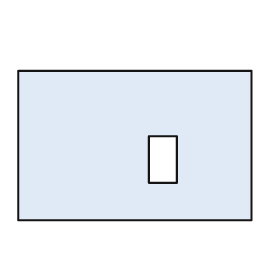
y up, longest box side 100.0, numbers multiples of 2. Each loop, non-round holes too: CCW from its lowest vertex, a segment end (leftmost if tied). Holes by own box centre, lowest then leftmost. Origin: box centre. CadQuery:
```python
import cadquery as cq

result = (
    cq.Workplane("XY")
    .moveTo(-50.0, -32.0)
    .lineTo(50.0, -32.0)
    .lineTo(50.0, 32.0)
    .lineTo(-50.0, 32.0)
    .close()
    .moveTo(6.0, -16.0)
    .lineTo(18.0, -16.0)
    .lineTo(18.0, 4.0)
    .lineTo(6.0, 4.0)
    .close()
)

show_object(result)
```